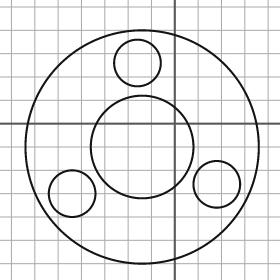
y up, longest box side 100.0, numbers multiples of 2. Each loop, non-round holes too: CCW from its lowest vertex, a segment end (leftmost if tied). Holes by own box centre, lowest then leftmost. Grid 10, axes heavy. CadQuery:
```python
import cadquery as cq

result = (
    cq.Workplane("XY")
    .moveTo(-14.0, -10.0)
    .circle(50.0)
    .moveTo(-44.0, -30.0)
    .circle(10.0)
    .moveTo(18.0, -26.0)
    .circle(10.0)
    .moveTo(-14.0, -10.0)
    .circle(22.0)
    .moveTo(-16.0, 26.0)
    .circle(10.0)
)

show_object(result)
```